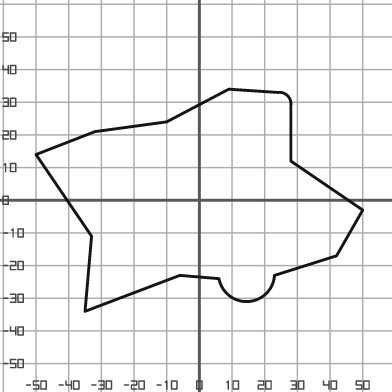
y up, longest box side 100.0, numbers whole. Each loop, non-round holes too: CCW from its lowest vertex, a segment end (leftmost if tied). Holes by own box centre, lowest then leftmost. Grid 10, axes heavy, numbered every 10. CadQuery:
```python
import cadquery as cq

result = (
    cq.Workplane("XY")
    .moveTo(-35.0, -34.0)
    .lineTo(-6.0, -23.0)
    .lineTo(6.0, -24.0)
    .threePointArc((15.0, -31.0), (23.0, -23.0))
    .lineTo(42.0, -17.0)
    .lineTo(50.0, -3.0)
    .lineTo(28.0, 12.0)
    .lineTo(28.0, 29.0)
    .threePointArc((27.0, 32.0), (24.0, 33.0))
    .lineTo(9.0, 34.0)
    .lineTo(-10.0, 24.0)
    .lineTo(-32.0, 21.0)
    .lineTo(-50.0, 14.0)
    .lineTo(-33.0, -11.0)
    .close()
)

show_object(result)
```